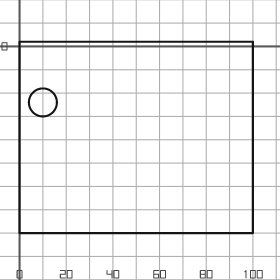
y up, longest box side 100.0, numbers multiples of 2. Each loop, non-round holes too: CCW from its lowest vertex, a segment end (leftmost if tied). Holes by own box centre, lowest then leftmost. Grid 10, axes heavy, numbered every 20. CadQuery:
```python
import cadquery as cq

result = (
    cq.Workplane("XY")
    .moveTo(0.0, -80.0)
    .lineTo(100.0, -80.0)
    .lineTo(100.0, 2.0)
    .lineTo(0.0, 2.0)
    .close()
    .moveTo(10.0, -24.0)
    .circle(6.0)
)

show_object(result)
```